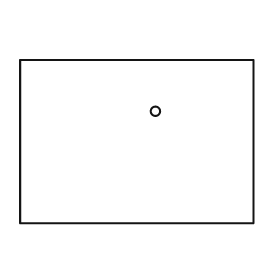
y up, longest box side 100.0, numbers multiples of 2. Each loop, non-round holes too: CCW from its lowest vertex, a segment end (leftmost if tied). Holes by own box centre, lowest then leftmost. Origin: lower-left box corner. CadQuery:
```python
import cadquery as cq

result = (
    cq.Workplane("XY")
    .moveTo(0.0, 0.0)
    .lineTo(100.0, 0.0)
    .lineTo(100.0, 70.0)
    .lineTo(0.0, 70.0)
    .close()
    .moveTo(58.0, 48.0)
    .circle(2.0)
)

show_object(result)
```